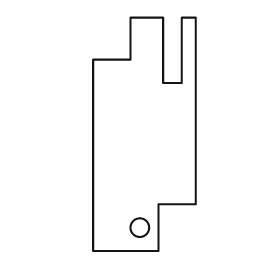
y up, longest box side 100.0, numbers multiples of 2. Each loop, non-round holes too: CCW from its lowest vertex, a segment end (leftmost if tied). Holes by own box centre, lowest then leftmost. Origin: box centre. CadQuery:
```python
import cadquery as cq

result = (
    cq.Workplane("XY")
    .moveTo(-22.0, -50.0)
    .lineTo(6.0, -50.0)
    .lineTo(6.0, -30.0)
    .lineTo(22.0, -30.0)
    .lineTo(22.0, 50.0)
    .lineTo(16.0, 50.0)
    .lineTo(16.0, 22.0)
    .lineTo(8.0, 22.0)
    .lineTo(8.0, 50.0)
    .lineTo(-6.0, 50.0)
    .lineTo(-6.0, 32.0)
    .lineTo(-22.0, 32.0)
    .close()
    .moveTo(-2.0, -40.0)
    .circle(4.0)
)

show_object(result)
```